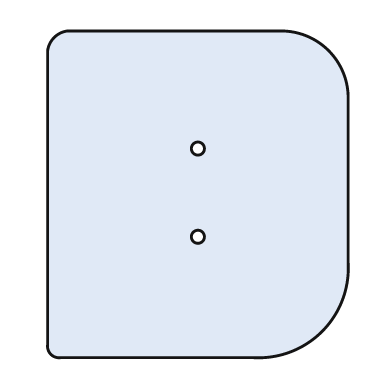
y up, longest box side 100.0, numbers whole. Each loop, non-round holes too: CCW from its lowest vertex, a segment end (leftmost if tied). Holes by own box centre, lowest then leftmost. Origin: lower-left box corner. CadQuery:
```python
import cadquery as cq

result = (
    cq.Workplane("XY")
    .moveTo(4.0, 0.0)
    .lineTo(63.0, 0.0)
    .threePointArc((84.0, 8.0), (92.0, 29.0))
    .lineTo(92.0, 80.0)
    .threePointArc((86.0, 94.0), (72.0, 100.0))
    .lineTo(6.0, 100.0)
    .threePointArc((2.0, 98.0), (0.0, 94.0))
    .lineTo(0.0, 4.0)
    .threePointArc((1.0, 1.0), (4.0, 0.0))
    .close()
    .moveTo(46.0, 37.0)
    .circle(2.0)
    .moveTo(46.0, 64.0)
    .circle(2.0)
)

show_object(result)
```